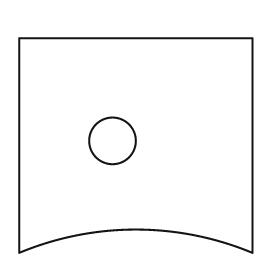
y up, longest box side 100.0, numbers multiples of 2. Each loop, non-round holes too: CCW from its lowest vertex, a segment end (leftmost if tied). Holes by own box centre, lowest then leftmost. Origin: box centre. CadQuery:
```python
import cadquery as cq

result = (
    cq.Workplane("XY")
    .moveTo(-50.0, -46.0)
    .threePointArc((0.0, -36.0), (50.0, -46.0))
    .lineTo(50.0, 46.0)
    .lineTo(-50.0, 46.0)
    .close()
    .moveTo(-10.0, 2.0)
    .circle(10.0)
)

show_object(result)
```